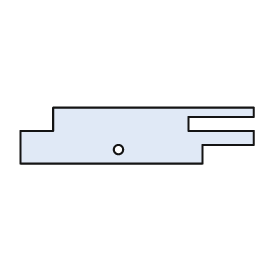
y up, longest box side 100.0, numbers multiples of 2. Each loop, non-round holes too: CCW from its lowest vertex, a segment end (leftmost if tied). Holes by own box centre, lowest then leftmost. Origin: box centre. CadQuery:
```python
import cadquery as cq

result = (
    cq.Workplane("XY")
    .moveTo(-50.0, -12.0)
    .lineTo(28.0, -12.0)
    .lineTo(28.0, -4.0)
    .lineTo(50.0, -4.0)
    .lineTo(50.0, 2.0)
    .lineTo(22.0, 2.0)
    .lineTo(22.0, 8.0)
    .lineTo(50.0, 8.0)
    .lineTo(50.0, 12.0)
    .lineTo(-36.0, 12.0)
    .lineTo(-36.0, 2.0)
    .lineTo(-50.0, 2.0)
    .close()
    .moveTo(-8.0, -6.0)
    .circle(2.0)
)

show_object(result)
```